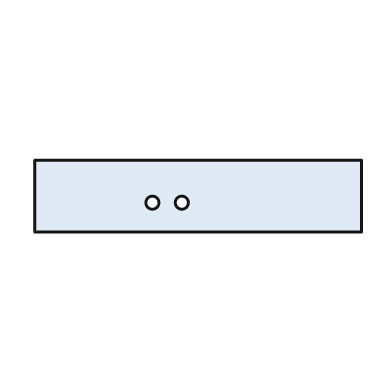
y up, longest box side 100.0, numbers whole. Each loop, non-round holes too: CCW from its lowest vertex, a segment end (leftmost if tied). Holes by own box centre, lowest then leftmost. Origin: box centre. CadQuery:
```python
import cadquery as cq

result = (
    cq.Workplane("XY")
    .moveTo(-50.0, -11.0)
    .lineTo(50.0, -11.0)
    .lineTo(50.0, 11.0)
    .lineTo(-50.0, 11.0)
    .close()
    .moveTo(-14.0, -2.0)
    .circle(2.0)
    .moveTo(-5.0, -2.0)
    .circle(2.0)
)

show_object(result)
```